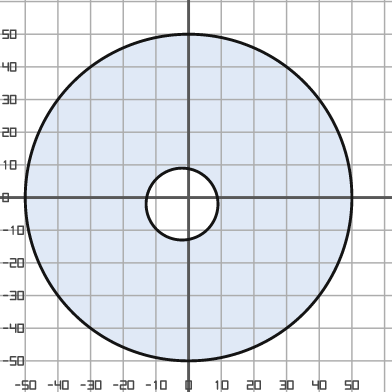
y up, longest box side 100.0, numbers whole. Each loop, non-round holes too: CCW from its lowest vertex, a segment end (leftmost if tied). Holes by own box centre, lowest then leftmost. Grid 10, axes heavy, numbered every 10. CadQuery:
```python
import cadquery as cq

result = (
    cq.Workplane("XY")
    .moveTo(0.0, 0.0)
    .circle(50.0)
    .moveTo(-2.0, -2.0)
    .circle(11.0)
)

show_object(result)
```